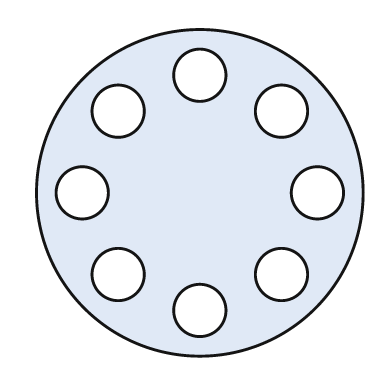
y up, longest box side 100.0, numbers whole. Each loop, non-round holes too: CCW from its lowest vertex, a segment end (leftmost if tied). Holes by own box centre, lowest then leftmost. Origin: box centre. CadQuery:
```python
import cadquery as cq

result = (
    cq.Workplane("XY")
    .moveTo(0.0, 0.0)
    .circle(50.0)
    .moveTo(0.0, -36.0)
    .circle(8.0)
    .moveTo(-25.0, -25.0)
    .circle(8.0)
    .moveTo(25.0, -25.0)
    .circle(8.0)
    .moveTo(-36.0, 0.0)
    .circle(8.0)
    .moveTo(36.0, 0.0)
    .circle(8.0)
    .moveTo(-25.0, 25.0)
    .circle(8.0)
    .moveTo(25.0, 25.0)
    .circle(8.0)
    .moveTo(0.0, 36.0)
    .circle(8.0)
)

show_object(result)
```